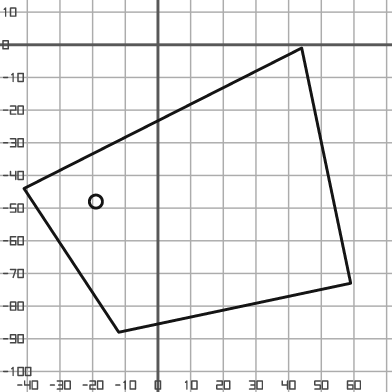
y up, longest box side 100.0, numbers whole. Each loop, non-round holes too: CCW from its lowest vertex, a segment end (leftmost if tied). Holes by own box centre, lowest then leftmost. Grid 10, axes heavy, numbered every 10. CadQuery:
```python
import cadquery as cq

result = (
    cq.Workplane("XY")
    .moveTo(-12.0, -88.0)
    .lineTo(59.0, -73.0)
    .lineTo(44.0, -1.0)
    .lineTo(-41.0, -44.0)
    .close()
    .moveTo(-19.0, -48.0)
    .circle(2.0)
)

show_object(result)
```